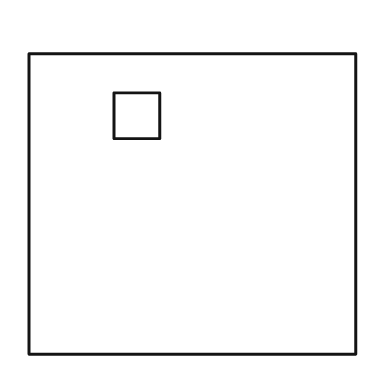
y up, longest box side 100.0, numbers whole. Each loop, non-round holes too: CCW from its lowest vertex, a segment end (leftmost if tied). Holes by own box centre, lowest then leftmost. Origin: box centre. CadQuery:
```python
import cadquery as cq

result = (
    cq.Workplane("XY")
    .moveTo(-50.0, -46.0)
    .lineTo(50.0, -46.0)
    .lineTo(50.0, 46.0)
    .lineTo(-50.0, 46.0)
    .close()
    .moveTo(-24.0, 20.0)
    .lineTo(-10.0, 20.0)
    .lineTo(-10.0, 34.0)
    .lineTo(-24.0, 34.0)
    .close()
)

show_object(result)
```